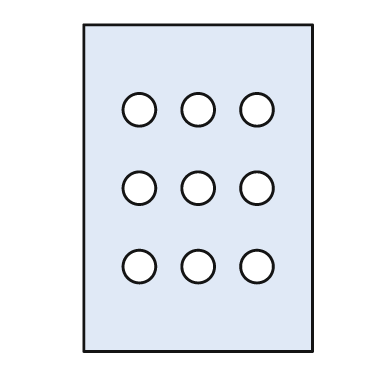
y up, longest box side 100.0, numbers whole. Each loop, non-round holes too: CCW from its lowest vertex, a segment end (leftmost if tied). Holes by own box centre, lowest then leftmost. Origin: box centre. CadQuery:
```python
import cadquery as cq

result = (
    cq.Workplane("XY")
    .moveTo(-35.0, -50.0)
    .lineTo(35.0, -50.0)
    .lineTo(35.0, 50.0)
    .lineTo(-35.0, 50.0)
    .close()
    .moveTo(-18.0, -24.0)
    .circle(5.0)
    .moveTo(0.0, -24.0)
    .circle(5.0)
    .moveTo(18.0, -24.0)
    .circle(5.0)
    .moveTo(-18.0, 0.0)
    .circle(5.0)
    .moveTo(0.0, 0.0)
    .circle(5.0)
    .moveTo(18.0, 0.0)
    .circle(5.0)
    .moveTo(-18.0, 24.0)
    .circle(5.0)
    .moveTo(0.0, 24.0)
    .circle(5.0)
    .moveTo(18.0, 24.0)
    .circle(5.0)
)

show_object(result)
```